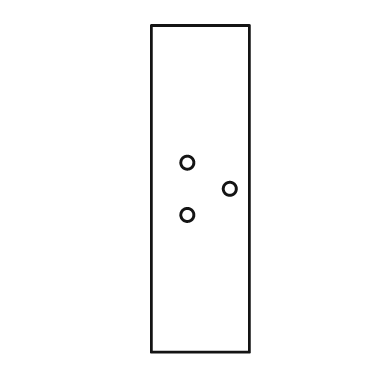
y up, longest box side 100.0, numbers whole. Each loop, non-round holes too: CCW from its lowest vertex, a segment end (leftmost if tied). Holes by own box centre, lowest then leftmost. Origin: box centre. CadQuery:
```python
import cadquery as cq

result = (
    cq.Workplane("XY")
    .moveTo(-15.0, -50.0)
    .lineTo(15.0, -50.0)
    .lineTo(15.0, 50.0)
    .lineTo(-15.0, 50.0)
    .close()
    .moveTo(-4.0, -8.0)
    .circle(2.0)
    .moveTo(9.0, 0.0)
    .circle(2.0)
    .moveTo(-4.0, 8.0)
    .circle(2.0)
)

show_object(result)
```